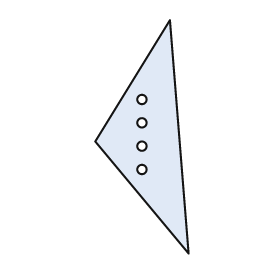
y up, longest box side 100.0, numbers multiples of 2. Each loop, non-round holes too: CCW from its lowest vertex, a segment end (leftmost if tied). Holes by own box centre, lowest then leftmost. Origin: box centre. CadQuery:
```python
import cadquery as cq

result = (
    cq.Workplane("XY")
    .moveTo(20.0, -50.0)
    .lineTo(12.0, 50.0)
    .lineTo(-20.0, -2.0)
    .close()
    .moveTo(0.0, -14.0)
    .circle(2.0)
    .moveTo(0.0, -4.0)
    .circle(2.0)
    .moveTo(0.0, 6.0)
    .circle(2.0)
    .moveTo(0.0, 16.0)
    .circle(2.0)
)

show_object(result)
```